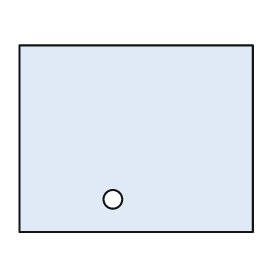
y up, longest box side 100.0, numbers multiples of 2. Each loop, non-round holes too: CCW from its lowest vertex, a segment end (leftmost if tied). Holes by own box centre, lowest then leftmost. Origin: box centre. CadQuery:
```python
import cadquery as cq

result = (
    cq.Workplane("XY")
    .moveTo(-50.0, -40.0)
    .lineTo(50.0, -40.0)
    .lineTo(50.0, 40.0)
    .lineTo(-50.0, 40.0)
    .close()
    .moveTo(-10.0, -26.0)
    .circle(4.0)
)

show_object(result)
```